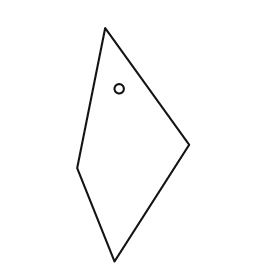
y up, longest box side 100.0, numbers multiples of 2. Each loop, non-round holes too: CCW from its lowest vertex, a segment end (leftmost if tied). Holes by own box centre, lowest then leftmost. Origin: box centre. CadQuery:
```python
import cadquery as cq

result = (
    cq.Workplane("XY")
    .moveTo(-8.0, -50.0)
    .lineTo(24.0, 0.0)
    .lineTo(-12.0, 50.0)
    .lineTo(-24.0, -10.0)
    .close()
    .moveTo(-6.0, 24.0)
    .circle(2.0)
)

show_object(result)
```